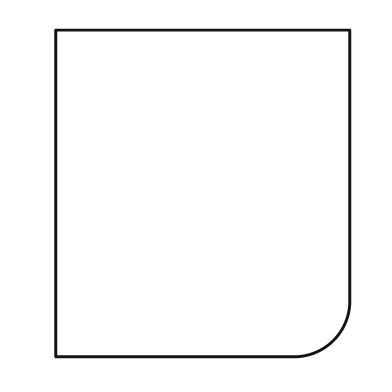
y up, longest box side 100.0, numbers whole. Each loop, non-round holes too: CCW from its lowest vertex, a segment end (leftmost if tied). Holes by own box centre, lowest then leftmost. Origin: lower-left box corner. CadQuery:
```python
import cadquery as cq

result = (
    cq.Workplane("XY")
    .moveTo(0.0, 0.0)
    .lineTo(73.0, 0.0)
    .threePointArc((85.0, 5.0), (90.0, 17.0))
    .lineTo(90.0, 100.0)
    .lineTo(0.0, 100.0)
    .close()
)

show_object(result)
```